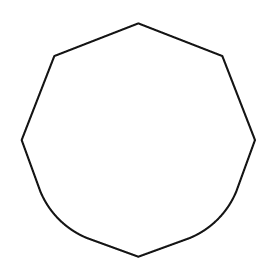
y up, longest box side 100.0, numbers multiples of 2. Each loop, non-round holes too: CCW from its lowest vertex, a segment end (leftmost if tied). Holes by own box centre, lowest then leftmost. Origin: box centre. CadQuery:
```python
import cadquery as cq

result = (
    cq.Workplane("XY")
    .moveTo(0.0, -50.0)
    .lineTo(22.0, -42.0)
    .threePointArc((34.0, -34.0), (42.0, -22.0))
    .lineTo(50.0, 0.0)
    .lineTo(36.0, 36.0)
    .lineTo(0.0, 50.0)
    .lineTo(-36.0, 36.0)
    .lineTo(-50.0, 0.0)
    .lineTo(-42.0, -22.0)
    .threePointArc((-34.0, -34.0), (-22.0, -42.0))
    .close()
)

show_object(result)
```